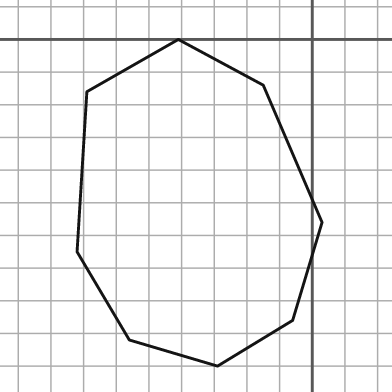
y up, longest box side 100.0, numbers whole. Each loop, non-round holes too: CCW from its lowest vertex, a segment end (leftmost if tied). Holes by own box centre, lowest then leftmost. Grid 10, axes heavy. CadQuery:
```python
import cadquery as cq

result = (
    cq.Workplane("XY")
    .moveTo(-29.0, -100.0)
    .lineTo(-6.0, -86.0)
    .lineTo(3.0, -56.0)
    .lineTo(-15.0, -14.0)
    .lineTo(-41.0, 0.0)
    .lineTo(-69.0, -16.0)
    .lineTo(-72.0, -65.0)
    .lineTo(-56.0, -92.0)
    .close()
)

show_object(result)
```